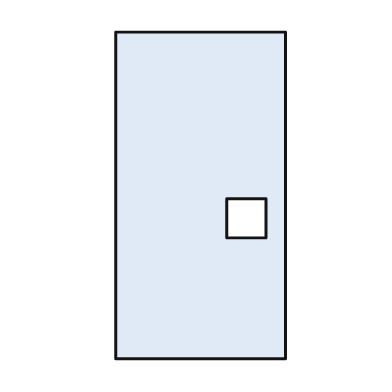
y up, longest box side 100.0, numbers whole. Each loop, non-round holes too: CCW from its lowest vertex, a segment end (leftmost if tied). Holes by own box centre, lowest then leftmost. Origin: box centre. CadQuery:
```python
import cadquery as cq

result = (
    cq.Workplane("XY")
    .moveTo(-26.0, -50.0)
    .lineTo(26.0, -50.0)
    .lineTo(26.0, 50.0)
    .lineTo(-26.0, 50.0)
    .close()
    .moveTo(8.0, -13.0)
    .lineTo(20.0, -13.0)
    .lineTo(20.0, -1.0)
    .lineTo(8.0, -1.0)
    .close()
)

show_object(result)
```